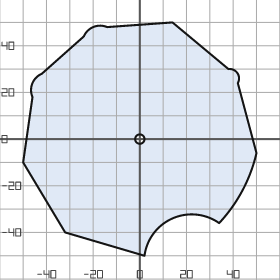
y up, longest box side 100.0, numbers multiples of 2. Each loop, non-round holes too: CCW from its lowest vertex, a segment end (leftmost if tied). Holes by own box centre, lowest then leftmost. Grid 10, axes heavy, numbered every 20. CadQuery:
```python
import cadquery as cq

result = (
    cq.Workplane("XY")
    .moveTo(2.0, -50.0)
    .threePointArc((14.0, -34.0), (34.0, -36.0))
    .threePointArc((44.0, -22.0), (50.0, -6.0))
    .lineTo(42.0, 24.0)
    .threePointArc((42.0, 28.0), (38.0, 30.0))
    .lineTo(14.0, 50.0)
    .lineTo(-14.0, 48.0)
    .threePointArc((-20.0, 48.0), (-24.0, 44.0))
    .lineTo(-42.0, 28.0)
    .threePointArc((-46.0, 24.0), (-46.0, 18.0))
    .lineTo(-50.0, -10.0)
    .lineTo(-32.0, -40.0)
    .close()
    .moveTo(0.0, 0.0)
    .circle(2.0)
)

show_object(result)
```